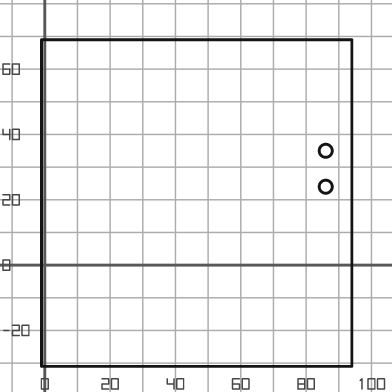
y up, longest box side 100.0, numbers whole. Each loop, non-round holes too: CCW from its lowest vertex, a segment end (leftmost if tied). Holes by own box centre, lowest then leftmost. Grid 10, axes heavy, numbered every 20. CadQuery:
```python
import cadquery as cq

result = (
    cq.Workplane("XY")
    .moveTo(-1.0, -31.0)
    .lineTo(94.0, -31.0)
    .lineTo(94.0, 69.0)
    .lineTo(-1.0, 69.0)
    .close()
    .moveTo(86.0, 24.0)
    .circle(2.0)
    .moveTo(86.0, 35.0)
    .circle(2.0)
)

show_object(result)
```